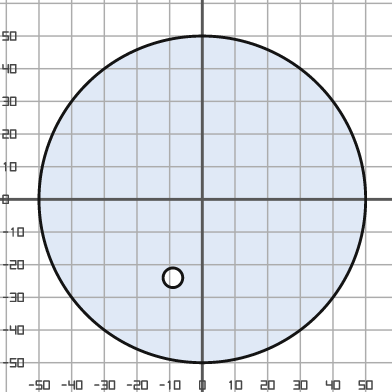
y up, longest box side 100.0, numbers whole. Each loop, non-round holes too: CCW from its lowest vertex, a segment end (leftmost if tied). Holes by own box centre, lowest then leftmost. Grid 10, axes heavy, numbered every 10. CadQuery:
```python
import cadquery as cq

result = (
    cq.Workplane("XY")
    .moveTo(0.0, 0.0)
    .circle(50.0)
    .moveTo(-9.0, -24.0)
    .circle(3.0)
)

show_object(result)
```